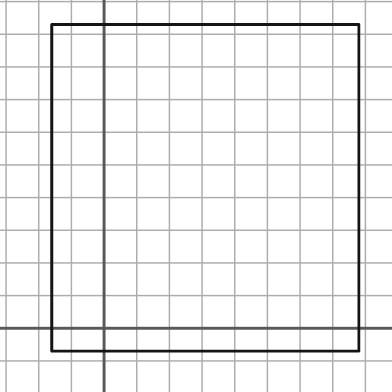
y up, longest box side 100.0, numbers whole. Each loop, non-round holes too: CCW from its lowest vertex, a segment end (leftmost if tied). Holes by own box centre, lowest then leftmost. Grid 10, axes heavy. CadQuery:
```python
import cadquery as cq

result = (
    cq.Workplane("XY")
    .moveTo(-16.0, -7.0)
    .lineTo(78.0, -7.0)
    .lineTo(78.0, 93.0)
    .lineTo(-16.0, 93.0)
    .close()
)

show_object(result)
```